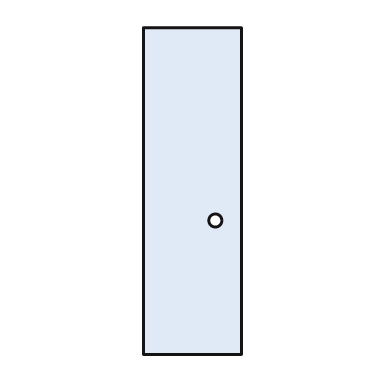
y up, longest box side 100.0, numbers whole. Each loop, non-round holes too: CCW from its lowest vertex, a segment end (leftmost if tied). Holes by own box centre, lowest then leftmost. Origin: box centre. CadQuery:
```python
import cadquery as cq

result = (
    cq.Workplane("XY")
    .moveTo(-15.0, -50.0)
    .lineTo(15.0, -50.0)
    .lineTo(15.0, 50.0)
    .lineTo(-15.0, 50.0)
    .close()
    .moveTo(7.0, -9.0)
    .circle(2.0)
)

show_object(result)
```